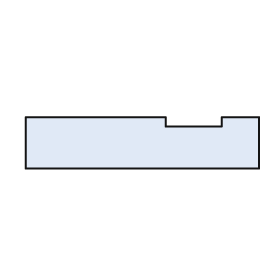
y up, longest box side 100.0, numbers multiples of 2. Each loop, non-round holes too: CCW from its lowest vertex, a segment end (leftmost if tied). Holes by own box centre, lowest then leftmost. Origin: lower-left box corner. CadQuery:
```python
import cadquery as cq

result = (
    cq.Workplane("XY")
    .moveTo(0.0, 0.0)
    .lineTo(100.0, 0.0)
    .lineTo(100.0, 22.0)
    .lineTo(84.0, 22.0)
    .lineTo(84.0, 18.0)
    .lineTo(60.0, 18.0)
    .lineTo(60.0, 22.0)
    .lineTo(0.0, 22.0)
    .close()
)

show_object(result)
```